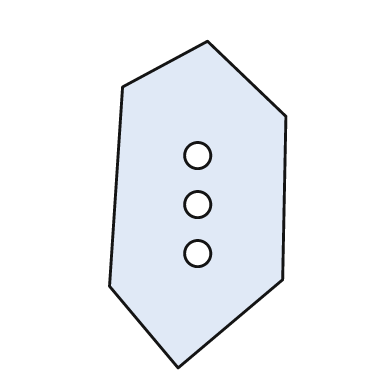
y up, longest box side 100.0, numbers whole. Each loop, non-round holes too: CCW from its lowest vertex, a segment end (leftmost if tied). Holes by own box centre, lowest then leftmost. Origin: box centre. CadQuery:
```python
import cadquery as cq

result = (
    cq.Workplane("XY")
    .moveTo(-6.0, -50.0)
    .lineTo(26.0, -23.0)
    .lineTo(27.0, 27.0)
    .lineTo(3.0, 50.0)
    .lineTo(-23.0, 36.0)
    .lineTo(-27.0, -25.0)
    .close()
    .moveTo(0.0, -15.0)
    .circle(4.0)
    .moveTo(0.0, 0.0)
    .circle(4.0)
    .moveTo(0.0, 15.0)
    .circle(4.0)
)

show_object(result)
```